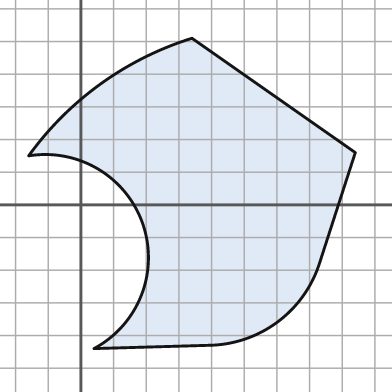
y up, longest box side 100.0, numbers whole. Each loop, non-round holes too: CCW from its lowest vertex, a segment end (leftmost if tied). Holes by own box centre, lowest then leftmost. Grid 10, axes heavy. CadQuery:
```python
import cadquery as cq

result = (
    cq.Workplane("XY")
    .moveTo(4.0, -44.0)
    .lineTo(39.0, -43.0)
    .threePointArc((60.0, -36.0), (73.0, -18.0))
    .lineTo(84.0, 16.0)
    .lineTo(34.0, 51.0)
    .threePointArc((6.0, 37.0), (-16.0, 15.0))
    .threePointArc((19.0, -6.0), (4.0, -44.0))
    .close()
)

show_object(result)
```